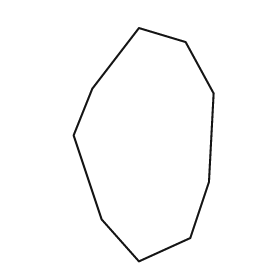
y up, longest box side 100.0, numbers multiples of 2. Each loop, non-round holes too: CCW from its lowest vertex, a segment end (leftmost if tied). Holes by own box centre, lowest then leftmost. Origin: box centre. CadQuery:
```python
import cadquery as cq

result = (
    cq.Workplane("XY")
    .moveTo(-2.0, -50.0)
    .lineTo(20.0, -40.0)
    .lineTo(28.0, -16.0)
    .lineTo(30.0, 22.0)
    .lineTo(18.0, 44.0)
    .lineTo(-2.0, 50.0)
    .lineTo(-22.0, 24.0)
    .lineTo(-30.0, 4.0)
    .lineTo(-18.0, -32.0)
    .close()
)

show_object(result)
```